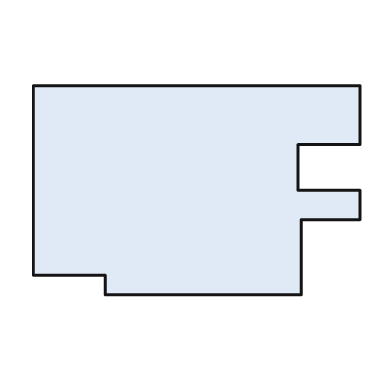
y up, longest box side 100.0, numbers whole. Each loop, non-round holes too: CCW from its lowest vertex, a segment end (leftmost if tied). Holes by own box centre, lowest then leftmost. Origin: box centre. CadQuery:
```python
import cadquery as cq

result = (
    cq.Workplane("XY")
    .moveTo(-28.0, -32.0)
    .lineTo(32.0, -32.0)
    .lineTo(32.0, -9.0)
    .lineTo(50.0, -9.0)
    .lineTo(50.0, 0.0)
    .lineTo(31.0, 0.0)
    .lineTo(31.0, 14.0)
    .lineTo(50.0, 14.0)
    .lineTo(50.0, 32.0)
    .lineTo(-50.0, 32.0)
    .lineTo(-50.0, -26.0)
    .lineTo(-28.0, -26.0)
    .close()
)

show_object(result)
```